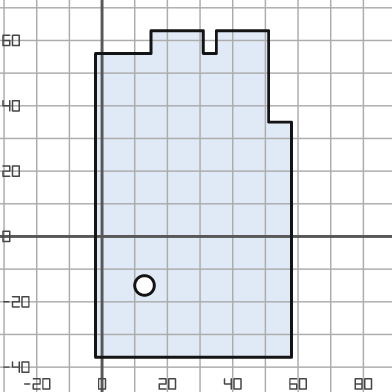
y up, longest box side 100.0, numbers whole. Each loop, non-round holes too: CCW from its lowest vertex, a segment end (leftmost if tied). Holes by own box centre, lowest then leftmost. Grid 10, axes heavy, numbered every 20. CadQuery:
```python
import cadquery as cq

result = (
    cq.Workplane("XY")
    .moveTo(-2.0, -37.0)
    .lineTo(58.0, -37.0)
    .lineTo(58.0, 35.0)
    .lineTo(51.0, 35.0)
    .lineTo(51.0, 63.0)
    .lineTo(35.0, 63.0)
    .lineTo(35.0, 56.0)
    .lineTo(31.0, 56.0)
    .lineTo(31.0, 63.0)
    .lineTo(15.0, 63.0)
    .lineTo(15.0, 56.0)
    .lineTo(-2.0, 56.0)
    .close()
    .moveTo(13.0, -15.0)
    .circle(3.0)
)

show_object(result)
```